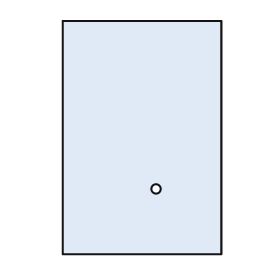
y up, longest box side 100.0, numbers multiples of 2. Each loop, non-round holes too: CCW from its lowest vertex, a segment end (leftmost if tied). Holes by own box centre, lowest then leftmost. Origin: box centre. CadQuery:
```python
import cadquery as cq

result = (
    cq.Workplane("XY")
    .moveTo(-34.0, -50.0)
    .lineTo(34.0, -50.0)
    .lineTo(34.0, 50.0)
    .lineTo(-34.0, 50.0)
    .close()
    .moveTo(6.0, -22.0)
    .circle(2.0)
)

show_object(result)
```